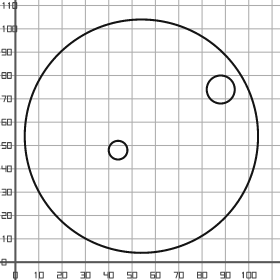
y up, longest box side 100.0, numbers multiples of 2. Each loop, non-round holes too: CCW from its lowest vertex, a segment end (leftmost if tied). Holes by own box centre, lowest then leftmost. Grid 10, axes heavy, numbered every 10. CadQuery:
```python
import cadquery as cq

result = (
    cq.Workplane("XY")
    .moveTo(54.0, 54.0)
    .circle(50.0)
    .moveTo(44.0, 48.0)
    .circle(4.0)
    .moveTo(88.0, 74.0)
    .circle(6.0)
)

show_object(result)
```